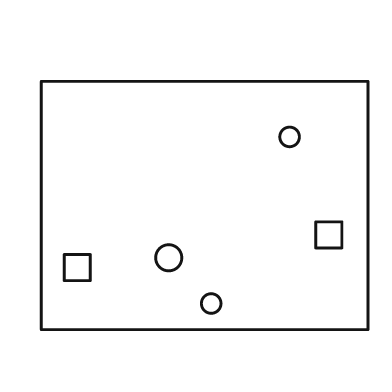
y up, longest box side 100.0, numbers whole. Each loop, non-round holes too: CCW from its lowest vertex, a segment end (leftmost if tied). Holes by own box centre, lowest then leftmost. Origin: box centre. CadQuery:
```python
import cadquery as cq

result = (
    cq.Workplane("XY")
    .moveTo(-50.0, -38.0)
    .lineTo(50.0, -38.0)
    .lineTo(50.0, 38.0)
    .lineTo(-50.0, 38.0)
    .close()
    .moveTo(2.0, -30.0)
    .circle(3.0)
    .moveTo(-43.0, -23.0)
    .lineTo(-35.0, -23.0)
    .lineTo(-35.0, -15.0)
    .lineTo(-43.0, -15.0)
    .close()
    .moveTo(-11.0, -16.0)
    .circle(4.0)
    .moveTo(34.0, -13.0)
    .lineTo(42.0, -13.0)
    .lineTo(42.0, -5.0)
    .lineTo(34.0, -5.0)
    .close()
    .moveTo(26.0, 21.0)
    .circle(3.0)
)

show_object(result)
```